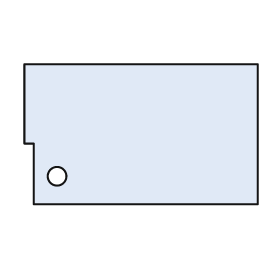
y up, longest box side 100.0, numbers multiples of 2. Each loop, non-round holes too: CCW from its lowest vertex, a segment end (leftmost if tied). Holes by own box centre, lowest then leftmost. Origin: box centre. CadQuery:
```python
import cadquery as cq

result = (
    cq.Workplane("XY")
    .moveTo(-46.0, -30.0)
    .lineTo(50.0, -30.0)
    .lineTo(50.0, 30.0)
    .lineTo(-50.0, 30.0)
    .lineTo(-50.0, -4.0)
    .lineTo(-46.0, -4.0)
    .close()
    .moveTo(-36.0, -18.0)
    .circle(4.0)
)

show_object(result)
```